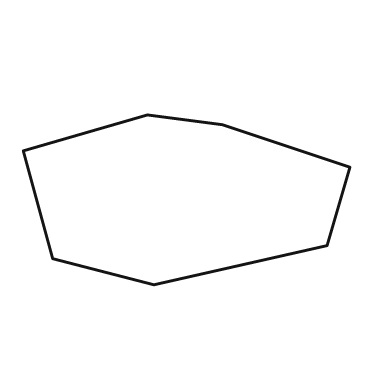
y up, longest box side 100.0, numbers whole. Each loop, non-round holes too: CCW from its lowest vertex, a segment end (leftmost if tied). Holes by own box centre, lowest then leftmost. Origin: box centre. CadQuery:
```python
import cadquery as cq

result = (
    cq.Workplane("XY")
    .moveTo(-10.0, -26.0)
    .lineTo(43.0, -14.0)
    .lineTo(50.0, 10.0)
    .lineTo(11.0, 23.0)
    .lineTo(-12.0, 26.0)
    .lineTo(-50.0, 15.0)
    .lineTo(-41.0, -18.0)
    .close()
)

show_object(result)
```